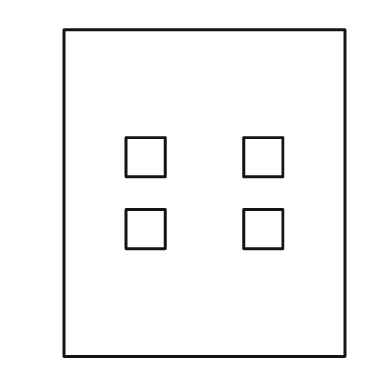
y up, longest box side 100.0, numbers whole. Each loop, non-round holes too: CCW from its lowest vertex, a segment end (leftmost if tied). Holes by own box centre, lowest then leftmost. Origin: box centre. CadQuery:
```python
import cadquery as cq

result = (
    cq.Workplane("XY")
    .moveTo(-43.0, -50.0)
    .lineTo(43.0, -50.0)
    .lineTo(43.0, 50.0)
    .lineTo(-43.0, 50.0)
    .close()
    .moveTo(-24.0, -17.0)
    .lineTo(-12.0, -17.0)
    .lineTo(-12.0, -5.0)
    .lineTo(-24.0, -5.0)
    .close()
    .moveTo(12.0, -17.0)
    .lineTo(24.0, -17.0)
    .lineTo(24.0, -5.0)
    .lineTo(12.0, -5.0)
    .close()
    .moveTo(-24.0, 5.0)
    .lineTo(-12.0, 5.0)
    .lineTo(-12.0, 17.0)
    .lineTo(-24.0, 17.0)
    .close()
    .moveTo(12.0, 5.0)
    .lineTo(24.0, 5.0)
    .lineTo(24.0, 17.0)
    .lineTo(12.0, 17.0)
    .close()
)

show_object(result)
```